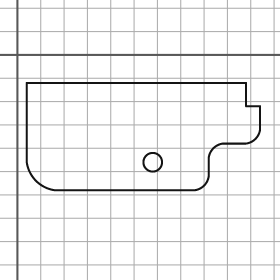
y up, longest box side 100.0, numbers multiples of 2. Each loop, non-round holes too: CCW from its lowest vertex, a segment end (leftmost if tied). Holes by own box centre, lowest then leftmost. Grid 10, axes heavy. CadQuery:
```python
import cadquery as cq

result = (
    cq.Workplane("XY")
    .moveTo(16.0, -58.0)
    .lineTo(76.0, -58.0)
    .threePointArc((80.0, -56.0), (82.0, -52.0))
    .lineTo(82.0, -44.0)
    .threePointArc((84.0, -40.0), (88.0, -38.0))
    .lineTo(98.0, -38.0)
    .threePointArc((102.0, -36.0), (104.0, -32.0))
    .lineTo(104.0, -22.0)
    .lineTo(98.0, -22.0)
    .lineTo(98.0, -12.0)
    .lineTo(4.0, -12.0)
    .lineTo(4.0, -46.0)
    .threePointArc((8.0, -54.0), (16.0, -58.0))
    .close()
    .moveTo(58.0, -46.0)
    .circle(4.0)
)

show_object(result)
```